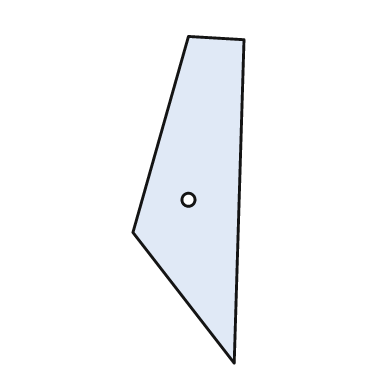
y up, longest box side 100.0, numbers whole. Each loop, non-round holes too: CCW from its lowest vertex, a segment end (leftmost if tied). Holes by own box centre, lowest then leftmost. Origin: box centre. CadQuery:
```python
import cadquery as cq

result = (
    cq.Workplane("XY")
    .moveTo(14.0, -50.0)
    .lineTo(17.0, 49.0)
    .lineTo(0.0, 50.0)
    .lineTo(-17.0, -10.0)
    .close()
    .moveTo(0.0, 0.0)
    .circle(2.0)
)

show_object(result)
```